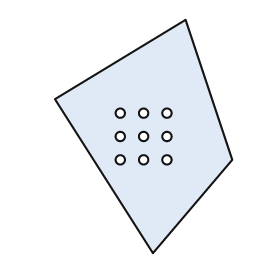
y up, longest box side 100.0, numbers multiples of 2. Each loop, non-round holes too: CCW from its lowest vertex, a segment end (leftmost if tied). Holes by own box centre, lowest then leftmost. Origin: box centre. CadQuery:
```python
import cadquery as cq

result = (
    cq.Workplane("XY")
    .moveTo(4.0, -50.0)
    .lineTo(38.0, -10.0)
    .lineTo(18.0, 50.0)
    .lineTo(-38.0, 16.0)
    .close()
    .moveTo(-10.0, -10.0)
    .circle(2.0)
    .moveTo(0.0, -10.0)
    .circle(2.0)
    .moveTo(10.0, -10.0)
    .circle(2.0)
    .moveTo(-10.0, 0.0)
    .circle(2.0)
    .moveTo(0.0, 0.0)
    .circle(2.0)
    .moveTo(10.0, 0.0)
    .circle(2.0)
    .moveTo(-10.0, 10.0)
    .circle(2.0)
    .moveTo(0.0, 10.0)
    .circle(2.0)
    .moveTo(10.0, 10.0)
    .circle(2.0)
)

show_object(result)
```